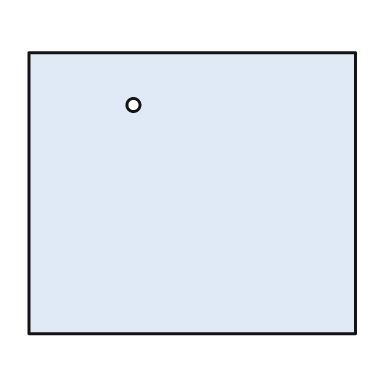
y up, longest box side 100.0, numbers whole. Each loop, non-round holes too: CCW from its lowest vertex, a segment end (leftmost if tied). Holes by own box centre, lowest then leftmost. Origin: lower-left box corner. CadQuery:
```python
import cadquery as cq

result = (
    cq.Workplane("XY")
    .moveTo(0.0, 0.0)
    .lineTo(100.0, 0.0)
    .lineTo(100.0, 86.0)
    .lineTo(0.0, 86.0)
    .close()
    .moveTo(32.0, 70.0)
    .circle(2.0)
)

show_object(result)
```